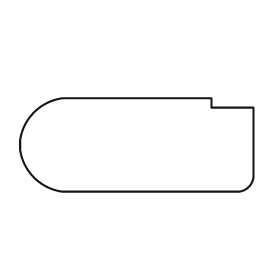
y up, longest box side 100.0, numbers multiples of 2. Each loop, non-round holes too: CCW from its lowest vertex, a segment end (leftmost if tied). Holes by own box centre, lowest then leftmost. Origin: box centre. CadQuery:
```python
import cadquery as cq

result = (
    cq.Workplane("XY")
    .moveTo(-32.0, -20.0)
    .lineTo(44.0, -20.0)
    .threePointArc((48.0, -18.0), (50.0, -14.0))
    .lineTo(50.0, 16.0)
    .lineTo(32.0, 16.0)
    .lineTo(32.0, 20.0)
    .lineTo(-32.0, 20.0)
    .threePointArc((-44.0, 14.0), (-50.0, 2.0))
    .lineTo(-50.0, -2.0)
    .threePointArc((-44.0, -14.0), (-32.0, -20.0))
    .close()
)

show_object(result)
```